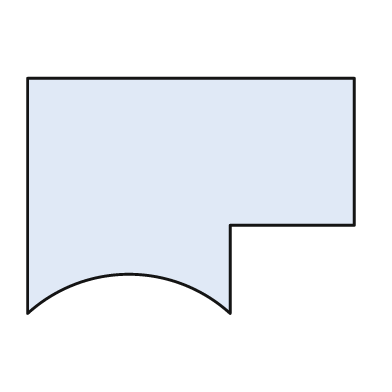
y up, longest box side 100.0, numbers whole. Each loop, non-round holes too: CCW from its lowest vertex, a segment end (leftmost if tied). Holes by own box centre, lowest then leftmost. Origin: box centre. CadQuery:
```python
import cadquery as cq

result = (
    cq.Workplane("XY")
    .moveTo(-50.0, -36.0)
    .threePointArc((-19.0, -24.0), (12.0, -36.0))
    .lineTo(12.0, -9.0)
    .lineTo(50.0, -9.0)
    .lineTo(50.0, 36.0)
    .lineTo(-50.0, 36.0)
    .close()
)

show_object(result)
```